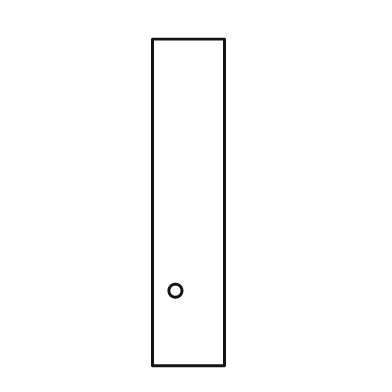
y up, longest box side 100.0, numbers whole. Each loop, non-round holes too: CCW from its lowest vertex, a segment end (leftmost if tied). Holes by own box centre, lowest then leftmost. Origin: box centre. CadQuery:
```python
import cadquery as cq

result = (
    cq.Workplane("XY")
    .moveTo(-11.0, -50.0)
    .lineTo(11.0, -50.0)
    .lineTo(11.0, 50.0)
    .lineTo(-11.0, 50.0)
    .close()
    .moveTo(-4.0, -27.0)
    .circle(2.0)
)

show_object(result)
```